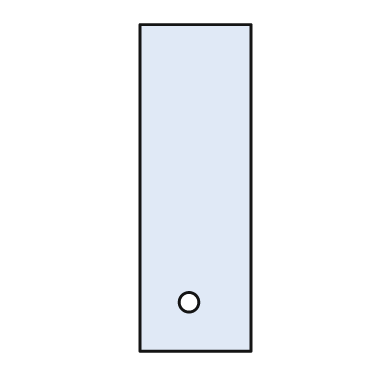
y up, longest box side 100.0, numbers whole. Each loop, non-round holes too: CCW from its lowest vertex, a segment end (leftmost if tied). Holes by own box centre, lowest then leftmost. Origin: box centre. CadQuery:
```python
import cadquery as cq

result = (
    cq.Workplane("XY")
    .moveTo(-17.0, -50.0)
    .lineTo(17.0, -50.0)
    .lineTo(17.0, 50.0)
    .lineTo(-17.0, 50.0)
    .close()
    .moveTo(-2.0, -35.0)
    .circle(3.0)
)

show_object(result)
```